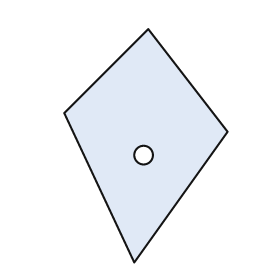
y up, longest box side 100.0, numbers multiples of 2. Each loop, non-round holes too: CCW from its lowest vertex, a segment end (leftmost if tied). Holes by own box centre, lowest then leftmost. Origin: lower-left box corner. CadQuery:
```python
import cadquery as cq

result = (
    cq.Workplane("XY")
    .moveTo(30.0, 0.0)
    .lineTo(70.0, 56.0)
    .lineTo(36.0, 100.0)
    .lineTo(0.0, 64.0)
    .close()
    .moveTo(34.0, 46.0)
    .circle(4.0)
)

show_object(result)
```